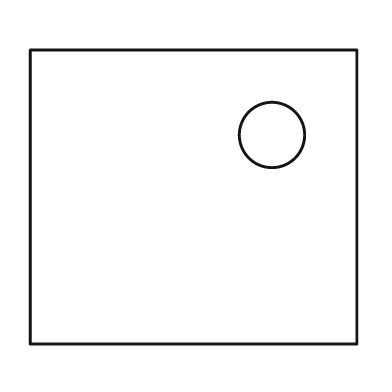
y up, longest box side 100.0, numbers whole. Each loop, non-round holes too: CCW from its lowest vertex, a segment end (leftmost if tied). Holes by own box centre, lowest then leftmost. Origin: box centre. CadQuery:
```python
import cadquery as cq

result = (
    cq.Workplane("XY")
    .moveTo(-50.0, -45.0)
    .lineTo(50.0, -45.0)
    .lineTo(50.0, 45.0)
    .lineTo(-50.0, 45.0)
    .close()
    .moveTo(24.0, 19.0)
    .circle(10.0)
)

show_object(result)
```